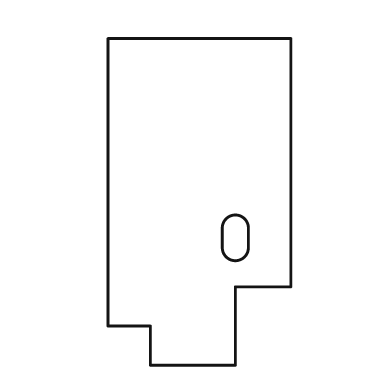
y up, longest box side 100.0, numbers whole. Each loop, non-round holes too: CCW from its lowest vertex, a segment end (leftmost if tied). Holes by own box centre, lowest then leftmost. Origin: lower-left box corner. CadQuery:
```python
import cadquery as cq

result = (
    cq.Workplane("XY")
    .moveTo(13.0, 0.0)
    .lineTo(39.0, 0.0)
    .lineTo(39.0, 24.0)
    .lineTo(56.0, 24.0)
    .lineTo(56.0, 100.0)
    .lineTo(0.0, 100.0)
    .lineTo(0.0, 12.0)
    .lineTo(13.0, 12.0)
    .close()
    .moveTo(35.0, 36.0)
    .threePointArc((39.0, 32.0), (43.0, 36.0))
    .lineTo(43.0, 42.0)
    .threePointArc((39.0, 46.0), (35.0, 42.0))
    .close()
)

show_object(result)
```